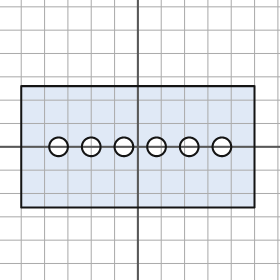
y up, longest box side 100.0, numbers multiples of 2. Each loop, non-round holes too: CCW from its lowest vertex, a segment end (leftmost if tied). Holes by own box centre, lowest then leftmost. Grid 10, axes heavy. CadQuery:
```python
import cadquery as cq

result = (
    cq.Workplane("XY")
    .moveTo(-50.0, -26.0)
    .lineTo(50.0, -26.0)
    .lineTo(50.0, 26.0)
    .lineTo(-50.0, 26.0)
    .close()
    .moveTo(-34.0, 0.0)
    .circle(4.0)
    .moveTo(-20.0, 0.0)
    .circle(4.0)
    .moveTo(-6.0, 0.0)
    .circle(4.0)
    .moveTo(8.0, 0.0)
    .circle(4.0)
    .moveTo(22.0, 0.0)
    .circle(4.0)
    .moveTo(36.0, 0.0)
    .circle(4.0)
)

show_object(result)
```